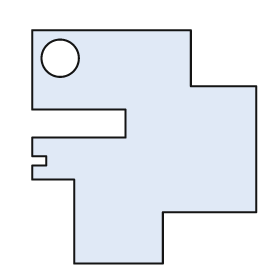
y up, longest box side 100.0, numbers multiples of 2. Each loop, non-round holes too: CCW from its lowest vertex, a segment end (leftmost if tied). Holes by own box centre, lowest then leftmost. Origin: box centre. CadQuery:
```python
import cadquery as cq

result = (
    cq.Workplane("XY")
    .moveTo(-30.0, -50.0)
    .lineTo(8.0, -50.0)
    .lineTo(8.0, -28.0)
    .lineTo(48.0, -28.0)
    .lineTo(48.0, 26.0)
    .lineTo(20.0, 26.0)
    .lineTo(20.0, 50.0)
    .lineTo(-48.0, 50.0)
    .lineTo(-48.0, 16.0)
    .lineTo(-8.0, 16.0)
    .lineTo(-8.0, 4.0)
    .lineTo(-48.0, 4.0)
    .lineTo(-48.0, -4.0)
    .lineTo(-42.0, -4.0)
    .lineTo(-42.0, -8.0)
    .lineTo(-48.0, -8.0)
    .lineTo(-48.0, -14.0)
    .lineTo(-30.0, -14.0)
    .close()
    .moveTo(-36.0, 38.0)
    .circle(8.0)
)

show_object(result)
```